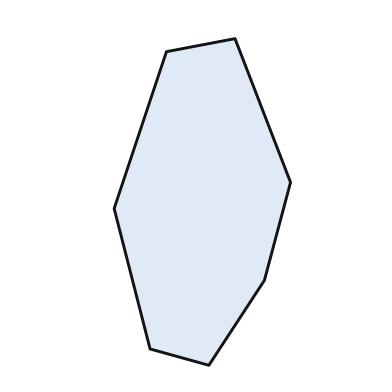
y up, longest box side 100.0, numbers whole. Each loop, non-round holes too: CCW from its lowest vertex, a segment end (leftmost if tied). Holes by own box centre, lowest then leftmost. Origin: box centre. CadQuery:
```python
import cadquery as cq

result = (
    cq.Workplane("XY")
    .moveTo(2.0, -50.0)
    .lineTo(19.0, -24.0)
    .lineTo(27.0, 6.0)
    .lineTo(10.0, 50.0)
    .lineTo(-11.0, 46.0)
    .lineTo(-27.0, -2.0)
    .lineTo(-16.0, -45.0)
    .close()
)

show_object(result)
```